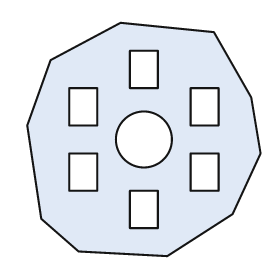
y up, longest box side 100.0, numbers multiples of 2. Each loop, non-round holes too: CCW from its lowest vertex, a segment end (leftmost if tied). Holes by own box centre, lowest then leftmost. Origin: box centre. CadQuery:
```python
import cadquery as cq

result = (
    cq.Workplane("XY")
    .moveTo(10.0, -50.0)
    .lineTo(38.0, -32.0)
    .lineTo(50.0, -6.0)
    .lineTo(46.0, 18.0)
    .lineTo(30.0, 46.0)
    .lineTo(-10.0, 50.0)
    .lineTo(-40.0, 34.0)
    .lineTo(-50.0, 6.0)
    .lineTo(-44.0, -34.0)
    .lineTo(-28.0, -48.0)
    .close()
    .moveTo(-6.0, -38.0)
    .lineTo(6.0, -38.0)
    .lineTo(6.0, -22.0)
    .lineTo(-6.0, -22.0)
    .close()
    .moveTo(-32.0, -22.0)
    .lineTo(-20.0, -22.0)
    .lineTo(-20.0, -6.0)
    .lineTo(-32.0, -6.0)
    .close()
    .moveTo(20.0, -22.0)
    .lineTo(32.0, -22.0)
    .lineTo(32.0, -6.0)
    .lineTo(20.0, -6.0)
    .close()
    .moveTo(0.0, 0.0)
    .circle(12.0)
    .moveTo(-32.0, 6.0)
    .lineTo(-20.0, 6.0)
    .lineTo(-20.0, 22.0)
    .lineTo(-32.0, 22.0)
    .close()
    .moveTo(20.0, 6.0)
    .lineTo(32.0, 6.0)
    .lineTo(32.0, 22.0)
    .lineTo(20.0, 22.0)
    .close()
    .moveTo(-6.0, 22.0)
    .lineTo(6.0, 22.0)
    .lineTo(6.0, 38.0)
    .lineTo(-6.0, 38.0)
    .close()
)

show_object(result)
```